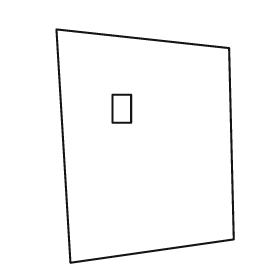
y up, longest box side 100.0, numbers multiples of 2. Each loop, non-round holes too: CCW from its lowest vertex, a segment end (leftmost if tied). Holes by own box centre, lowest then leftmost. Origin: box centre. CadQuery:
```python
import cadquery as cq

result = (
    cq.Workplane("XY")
    .moveTo(-32.0, -50.0)
    .lineTo(38.0, -40.0)
    .lineTo(36.0, 42.0)
    .lineTo(-38.0, 50.0)
    .close()
    .moveTo(-14.0, 10.0)
    .lineTo(-6.0, 10.0)
    .lineTo(-6.0, 22.0)
    .lineTo(-14.0, 22.0)
    .close()
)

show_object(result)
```